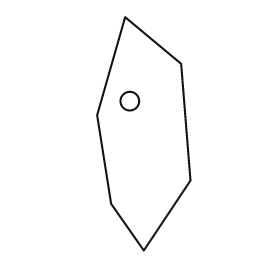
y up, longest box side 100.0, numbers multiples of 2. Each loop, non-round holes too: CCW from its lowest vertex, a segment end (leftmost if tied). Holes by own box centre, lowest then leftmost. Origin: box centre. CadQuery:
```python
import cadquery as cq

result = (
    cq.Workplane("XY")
    .moveTo(0.0, -50.0)
    .lineTo(20.0, -20.0)
    .lineTo(16.0, 30.0)
    .lineTo(-8.0, 50.0)
    .lineTo(-20.0, 8.0)
    .lineTo(-14.0, -30.0)
    .close()
    .moveTo(-6.0, 14.0)
    .circle(4.0)
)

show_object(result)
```